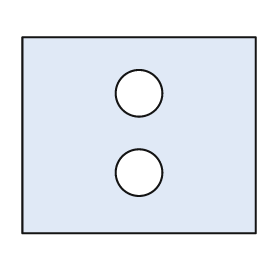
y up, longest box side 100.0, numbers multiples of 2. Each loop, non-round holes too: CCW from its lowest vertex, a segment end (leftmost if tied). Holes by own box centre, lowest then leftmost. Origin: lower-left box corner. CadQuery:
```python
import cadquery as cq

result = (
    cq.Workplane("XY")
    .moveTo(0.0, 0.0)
    .lineTo(100.0, 0.0)
    .lineTo(100.0, 84.0)
    .lineTo(0.0, 84.0)
    .close()
    .moveTo(50.0, 26.0)
    .circle(10.0)
    .moveTo(50.0, 60.0)
    .circle(10.0)
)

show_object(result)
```